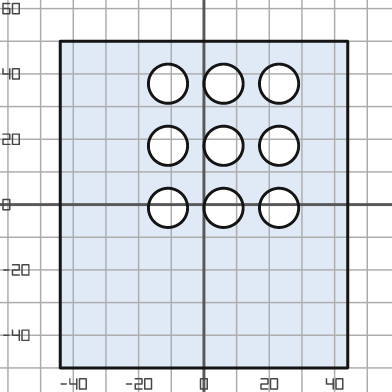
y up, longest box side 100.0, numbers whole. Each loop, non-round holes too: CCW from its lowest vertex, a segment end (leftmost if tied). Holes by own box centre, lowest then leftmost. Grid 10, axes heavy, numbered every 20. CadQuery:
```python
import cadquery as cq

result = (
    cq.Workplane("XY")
    .moveTo(-44.0, -50.0)
    .lineTo(44.0, -50.0)
    .lineTo(44.0, 50.0)
    .lineTo(-44.0, 50.0)
    .close()
    .moveTo(-11.0, -1.0)
    .circle(6.0)
    .moveTo(6.0, -1.0)
    .circle(6.0)
    .moveTo(23.0, -1.0)
    .circle(6.0)
    .moveTo(-11.0, 18.0)
    .circle(6.0)
    .moveTo(6.0, 18.0)
    .circle(6.0)
    .moveTo(23.0, 18.0)
    .circle(6.0)
    .moveTo(-11.0, 37.0)
    .circle(6.0)
    .moveTo(6.0, 37.0)
    .circle(6.0)
    .moveTo(23.0, 37.0)
    .circle(6.0)
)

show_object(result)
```